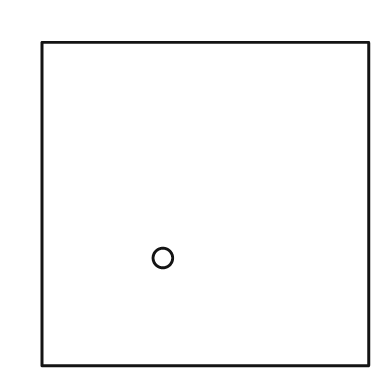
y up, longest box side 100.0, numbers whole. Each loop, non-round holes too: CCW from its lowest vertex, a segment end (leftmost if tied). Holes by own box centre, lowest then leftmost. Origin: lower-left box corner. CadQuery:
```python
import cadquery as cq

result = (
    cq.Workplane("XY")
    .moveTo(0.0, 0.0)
    .lineTo(100.0, 0.0)
    .lineTo(100.0, 99.0)
    .lineTo(0.0, 99.0)
    .close()
    .moveTo(37.0, 33.0)
    .circle(3.0)
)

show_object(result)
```